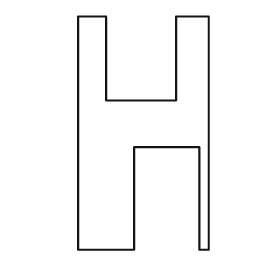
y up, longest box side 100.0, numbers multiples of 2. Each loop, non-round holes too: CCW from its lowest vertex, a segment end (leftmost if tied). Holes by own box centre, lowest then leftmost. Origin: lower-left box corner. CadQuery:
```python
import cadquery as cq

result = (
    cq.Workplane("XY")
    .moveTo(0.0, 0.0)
    .lineTo(24.0, 0.0)
    .lineTo(24.0, 44.0)
    .lineTo(52.0, 44.0)
    .lineTo(52.0, 0.0)
    .lineTo(56.0, 0.0)
    .lineTo(56.0, 100.0)
    .lineTo(42.0, 100.0)
    .lineTo(42.0, 64.0)
    .lineTo(12.0, 64.0)
    .lineTo(12.0, 100.0)
    .lineTo(0.0, 100.0)
    .close()
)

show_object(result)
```